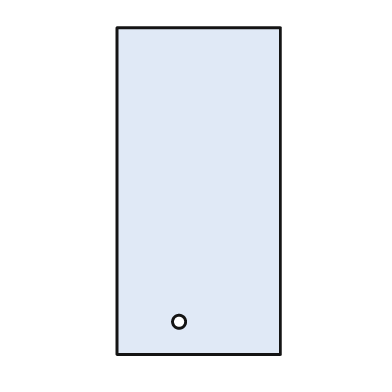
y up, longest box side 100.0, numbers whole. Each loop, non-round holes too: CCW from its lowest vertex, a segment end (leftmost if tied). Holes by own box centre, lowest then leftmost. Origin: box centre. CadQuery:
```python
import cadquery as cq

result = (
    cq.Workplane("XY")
    .moveTo(-25.0, -50.0)
    .lineTo(25.0, -50.0)
    .lineTo(25.0, 50.0)
    .lineTo(-25.0, 50.0)
    .close()
    .moveTo(-6.0, -40.0)
    .circle(2.0)
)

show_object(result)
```